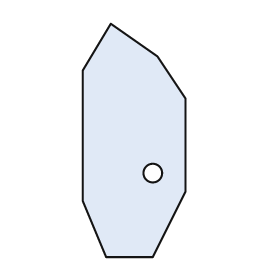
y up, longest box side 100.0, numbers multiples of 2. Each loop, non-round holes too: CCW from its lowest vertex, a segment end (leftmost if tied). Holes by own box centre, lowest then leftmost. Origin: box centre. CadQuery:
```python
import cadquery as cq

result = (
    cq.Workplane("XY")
    .moveTo(-12.0, -50.0)
    .lineTo(8.0, -50.0)
    .lineTo(22.0, -22.0)
    .lineTo(22.0, 18.0)
    .lineTo(10.0, 36.0)
    .lineTo(-10.0, 50.0)
    .lineTo(-22.0, 30.0)
    .lineTo(-22.0, -26.0)
    .close()
    .moveTo(8.0, -14.0)
    .circle(4.0)
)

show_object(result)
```